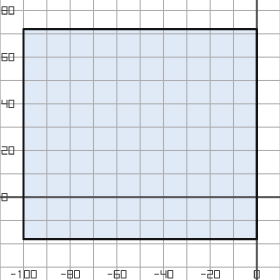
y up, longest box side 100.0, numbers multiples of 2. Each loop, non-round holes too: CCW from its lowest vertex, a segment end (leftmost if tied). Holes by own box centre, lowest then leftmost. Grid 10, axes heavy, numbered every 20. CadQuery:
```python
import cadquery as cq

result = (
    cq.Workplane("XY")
    .moveTo(-100.0, -18.0)
    .lineTo(0.0, -18.0)
    .lineTo(0.0, 72.0)
    .lineTo(-100.0, 72.0)
    .close()
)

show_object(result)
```